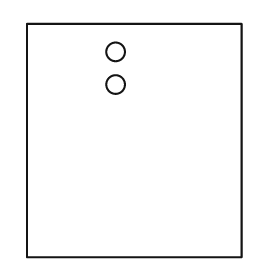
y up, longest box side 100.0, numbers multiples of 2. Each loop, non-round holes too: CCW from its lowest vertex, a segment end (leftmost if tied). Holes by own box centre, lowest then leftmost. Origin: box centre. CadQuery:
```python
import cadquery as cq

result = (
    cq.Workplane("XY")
    .moveTo(-46.0, -50.0)
    .lineTo(46.0, -50.0)
    .lineTo(46.0, 50.0)
    .lineTo(-46.0, 50.0)
    .close()
    .moveTo(-8.0, 24.0)
    .circle(4.0)
    .moveTo(-8.0, 38.0)
    .circle(4.0)
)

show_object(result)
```